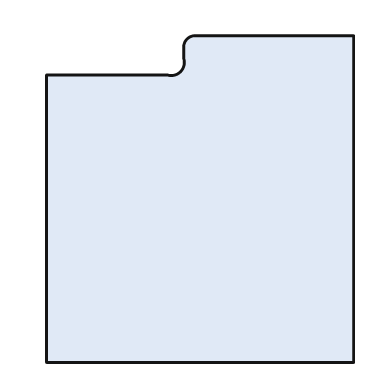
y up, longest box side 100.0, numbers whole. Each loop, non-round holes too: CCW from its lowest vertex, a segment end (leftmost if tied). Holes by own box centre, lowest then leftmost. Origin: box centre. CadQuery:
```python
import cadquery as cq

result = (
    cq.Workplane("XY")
    .moveTo(-47.0, -50.0)
    .lineTo(47.0, -50.0)
    .lineTo(47.0, 50.0)
    .lineTo(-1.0, 50.0)
    .threePointArc((-4.0, 49.0), (-5.0, 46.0))
    .lineTo(-5.0, 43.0)
    .threePointArc((-6.0, 39.0), (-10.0, 38.0))
    .lineTo(-47.0, 38.0)
    .close()
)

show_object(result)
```